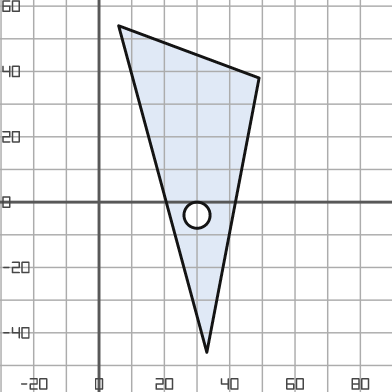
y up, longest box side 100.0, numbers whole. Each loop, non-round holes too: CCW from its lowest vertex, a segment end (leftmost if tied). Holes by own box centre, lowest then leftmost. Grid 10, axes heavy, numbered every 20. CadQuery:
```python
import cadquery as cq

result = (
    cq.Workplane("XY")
    .moveTo(33.0, -46.0)
    .lineTo(49.0, 38.0)
    .lineTo(6.0, 54.0)
    .close()
    .moveTo(30.0, -4.0)
    .circle(4.0)
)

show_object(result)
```